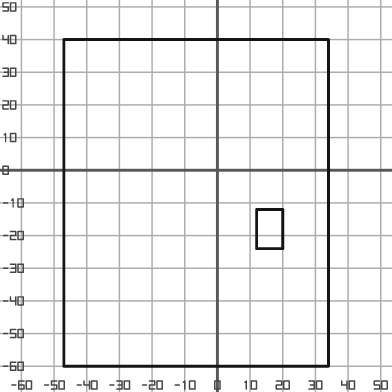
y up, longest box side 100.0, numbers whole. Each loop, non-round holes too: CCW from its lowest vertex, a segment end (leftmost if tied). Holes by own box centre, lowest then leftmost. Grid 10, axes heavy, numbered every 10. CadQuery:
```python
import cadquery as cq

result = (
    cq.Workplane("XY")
    .moveTo(-47.0, -60.0)
    .lineTo(34.0, -60.0)
    .lineTo(34.0, 40.0)
    .lineTo(-47.0, 40.0)
    .close()
    .moveTo(12.0, -24.0)
    .lineTo(20.0, -24.0)
    .lineTo(20.0, -12.0)
    .lineTo(12.0, -12.0)
    .close()
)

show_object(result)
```